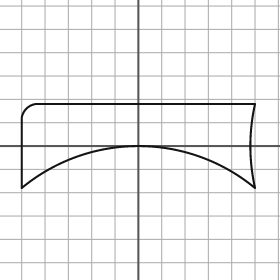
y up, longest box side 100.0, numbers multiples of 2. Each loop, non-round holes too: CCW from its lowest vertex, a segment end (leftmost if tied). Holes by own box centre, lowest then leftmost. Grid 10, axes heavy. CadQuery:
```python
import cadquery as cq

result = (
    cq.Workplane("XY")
    .moveTo(-50.0, -18.0)
    .threePointArc((0.0, 0.0), (50.0, -18.0))
    .threePointArc((48.0, 0.0), (50.0, 18.0))
    .lineTo(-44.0, 18.0)
    .threePointArc((-48.0, 16.0), (-50.0, 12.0))
    .close()
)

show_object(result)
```